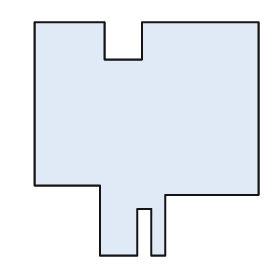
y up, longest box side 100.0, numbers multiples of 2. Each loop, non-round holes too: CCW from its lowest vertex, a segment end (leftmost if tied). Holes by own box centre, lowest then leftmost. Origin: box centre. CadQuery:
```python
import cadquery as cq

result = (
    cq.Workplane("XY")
    .moveTo(-20.0, -50.0)
    .lineTo(-4.0, -50.0)
    .lineTo(-4.0, -30.0)
    .lineTo(2.0, -30.0)
    .lineTo(2.0, -50.0)
    .lineTo(8.0, -50.0)
    .lineTo(8.0, -24.0)
    .lineTo(48.0, -24.0)
    .lineTo(48.0, 50.0)
    .lineTo(-2.0, 50.0)
    .lineTo(-2.0, 34.0)
    .lineTo(-18.0, 34.0)
    .lineTo(-18.0, 50.0)
    .lineTo(-48.0, 50.0)
    .lineTo(-48.0, -20.0)
    .lineTo(-20.0, -20.0)
    .close()
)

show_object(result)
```